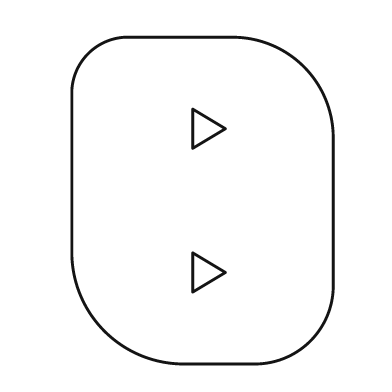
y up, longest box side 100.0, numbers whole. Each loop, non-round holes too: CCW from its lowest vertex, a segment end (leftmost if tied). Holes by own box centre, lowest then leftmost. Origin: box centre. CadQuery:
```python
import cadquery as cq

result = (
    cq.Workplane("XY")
    .moveTo(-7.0, -50.0)
    .lineTo(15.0, -50.0)
    .threePointArc((33.0, -43.0), (40.0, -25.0))
    .lineTo(40.0, 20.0)
    .threePointArc((31.0, 41.0), (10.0, 50.0))
    .lineTo(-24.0, 50.0)
    .threePointArc((-35.0, 45.0), (-40.0, 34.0))
    .lineTo(-40.0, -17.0)
    .threePointArc((-30.0, -40.0), (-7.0, -50.0))
    .close()
    .moveTo(-3.0, -28.0)
    .lineTo(7.0, -22.0)
    .lineTo(-3.0, -16.0)
    .close()
    .moveTo(-3.0, 16.0)
    .lineTo(7.0, 22.0)
    .lineTo(-3.0, 28.0)
    .close()
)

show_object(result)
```